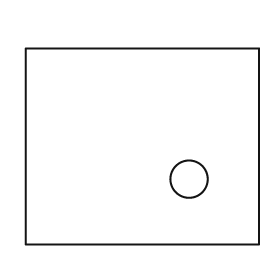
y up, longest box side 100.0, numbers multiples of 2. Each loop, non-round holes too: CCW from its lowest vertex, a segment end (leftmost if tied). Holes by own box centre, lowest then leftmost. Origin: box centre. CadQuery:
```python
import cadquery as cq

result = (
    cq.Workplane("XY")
    .moveTo(-50.0, -42.0)
    .lineTo(50.0, -42.0)
    .lineTo(50.0, 42.0)
    .lineTo(-50.0, 42.0)
    .close()
    .moveTo(20.0, -14.0)
    .circle(8.0)
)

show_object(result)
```